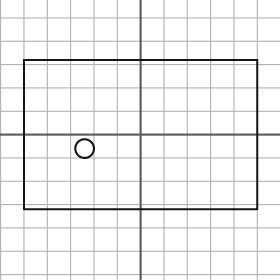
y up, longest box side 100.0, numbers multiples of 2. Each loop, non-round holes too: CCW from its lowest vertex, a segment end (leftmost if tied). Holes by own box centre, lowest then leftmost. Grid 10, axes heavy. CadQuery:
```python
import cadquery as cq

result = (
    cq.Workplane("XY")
    .moveTo(-50.0, -32.0)
    .lineTo(50.0, -32.0)
    .lineTo(50.0, 32.0)
    .lineTo(-50.0, 32.0)
    .close()
    .moveTo(-24.0, -6.0)
    .circle(4.0)
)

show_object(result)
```